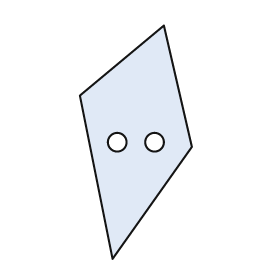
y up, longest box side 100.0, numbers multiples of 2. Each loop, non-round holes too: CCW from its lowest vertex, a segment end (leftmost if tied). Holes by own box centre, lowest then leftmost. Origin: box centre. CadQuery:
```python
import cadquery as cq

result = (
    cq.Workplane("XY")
    .moveTo(-10.0, -50.0)
    .lineTo(24.0, -2.0)
    .lineTo(12.0, 50.0)
    .lineTo(-24.0, 20.0)
    .close()
    .moveTo(-8.0, 0.0)
    .circle(4.0)
    .moveTo(8.0, 0.0)
    .circle(4.0)
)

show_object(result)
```